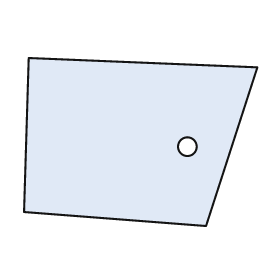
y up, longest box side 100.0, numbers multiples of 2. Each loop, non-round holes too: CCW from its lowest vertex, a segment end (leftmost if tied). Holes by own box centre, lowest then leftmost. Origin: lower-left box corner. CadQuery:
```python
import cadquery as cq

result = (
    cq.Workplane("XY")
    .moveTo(78.0, 0.0)
    .lineTo(100.0, 68.0)
    .lineTo(2.0, 72.0)
    .lineTo(0.0, 6.0)
    .close()
    .moveTo(70.0, 34.0)
    .circle(4.0)
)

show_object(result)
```